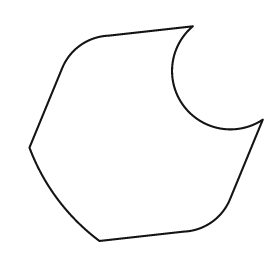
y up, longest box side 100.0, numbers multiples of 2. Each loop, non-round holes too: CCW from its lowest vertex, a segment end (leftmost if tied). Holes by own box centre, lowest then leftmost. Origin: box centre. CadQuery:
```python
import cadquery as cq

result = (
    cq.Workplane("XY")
    .moveTo(-20.0, -46.0)
    .lineTo(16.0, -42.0)
    .threePointArc((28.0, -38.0), (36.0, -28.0))
    .lineTo(50.0, 6.0)
    .threePointArc((16.0, 12.0), (20.0, 46.0))
    .lineTo(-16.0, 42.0)
    .threePointArc((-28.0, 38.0), (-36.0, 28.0))
    .lineTo(-50.0, -6.0)
    .threePointArc((-38.0, -28.0), (-20.0, -46.0))
    .close()
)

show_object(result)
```